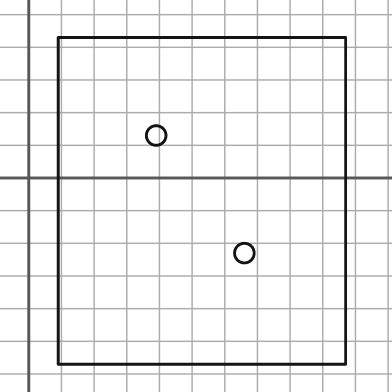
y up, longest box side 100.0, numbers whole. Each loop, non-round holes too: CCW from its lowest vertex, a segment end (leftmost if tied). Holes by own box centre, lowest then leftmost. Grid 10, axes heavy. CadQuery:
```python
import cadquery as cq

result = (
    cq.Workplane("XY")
    .moveTo(9.0, -57.0)
    .lineTo(97.0, -57.0)
    .lineTo(97.0, 43.0)
    .lineTo(9.0, 43.0)
    .close()
    .moveTo(66.0, -23.0)
    .circle(3.0)
    .moveTo(39.0, 13.0)
    .circle(3.0)
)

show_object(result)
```